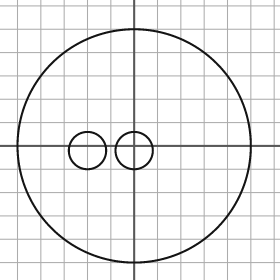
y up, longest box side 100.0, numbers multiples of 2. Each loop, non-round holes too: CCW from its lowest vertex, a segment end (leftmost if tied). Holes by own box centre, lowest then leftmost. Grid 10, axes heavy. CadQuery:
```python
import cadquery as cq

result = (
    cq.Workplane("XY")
    .moveTo(0.0, 0.0)
    .circle(50.0)
    .moveTo(-20.0, -2.0)
    .circle(8.0)
    .moveTo(0.0, -2.0)
    .circle(8.0)
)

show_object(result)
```